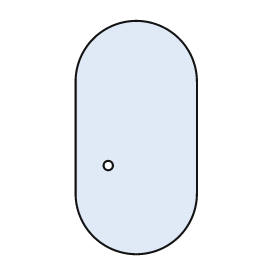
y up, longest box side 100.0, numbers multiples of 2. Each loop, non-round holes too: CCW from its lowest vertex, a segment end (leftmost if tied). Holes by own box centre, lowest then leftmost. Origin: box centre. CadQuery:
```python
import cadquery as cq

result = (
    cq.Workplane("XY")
    .moveTo(-26.0, -24.0)
    .threePointArc((0.0, -50.0), (26.0, -24.0))
    .lineTo(26.0, 24.0)
    .threePointArc((0.0, 50.0), (-26.0, 24.0))
    .close()
    .moveTo(-12.0, -12.0)
    .circle(2.0)
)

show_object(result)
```